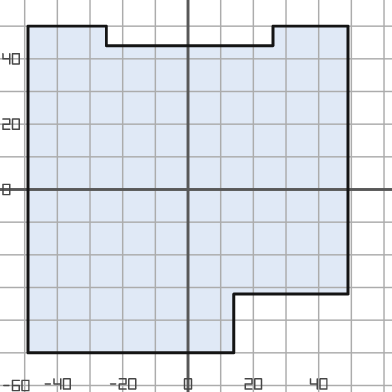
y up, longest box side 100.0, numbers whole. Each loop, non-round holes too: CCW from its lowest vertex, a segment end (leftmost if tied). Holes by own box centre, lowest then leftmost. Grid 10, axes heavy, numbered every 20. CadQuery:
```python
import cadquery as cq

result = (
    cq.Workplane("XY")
    .moveTo(-49.0, -50.0)
    .lineTo(14.0, -50.0)
    .lineTo(14.0, -32.0)
    .lineTo(49.0, -32.0)
    .lineTo(49.0, 50.0)
    .lineTo(26.0, 50.0)
    .lineTo(26.0, 44.0)
    .lineTo(-25.0, 44.0)
    .lineTo(-25.0, 50.0)
    .lineTo(-49.0, 50.0)
    .close()
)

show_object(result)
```